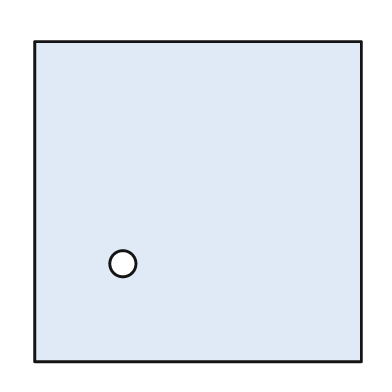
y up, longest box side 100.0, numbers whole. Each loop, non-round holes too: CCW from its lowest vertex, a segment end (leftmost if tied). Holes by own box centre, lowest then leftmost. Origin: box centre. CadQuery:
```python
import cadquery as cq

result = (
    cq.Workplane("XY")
    .moveTo(-50.0, -49.0)
    .lineTo(50.0, -49.0)
    .lineTo(50.0, 49.0)
    .lineTo(-50.0, 49.0)
    .close()
    .moveTo(-23.0, -19.0)
    .circle(4.0)
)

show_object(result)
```